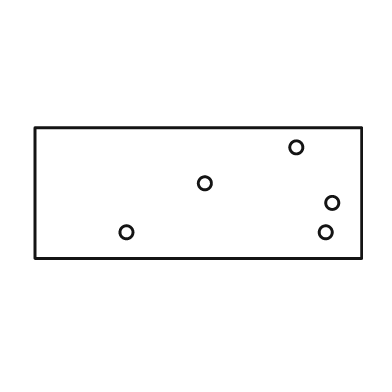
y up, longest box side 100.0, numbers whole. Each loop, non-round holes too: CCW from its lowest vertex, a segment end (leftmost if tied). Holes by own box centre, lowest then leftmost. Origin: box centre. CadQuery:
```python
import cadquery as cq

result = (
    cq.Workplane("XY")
    .moveTo(-50.0, -20.0)
    .lineTo(50.0, -20.0)
    .lineTo(50.0, 20.0)
    .lineTo(-50.0, 20.0)
    .close()
    .moveTo(-22.0, -12.0)
    .circle(2.0)
    .moveTo(39.0, -12.0)
    .circle(2.0)
    .moveTo(41.0, -3.0)
    .circle(2.0)
    .moveTo(2.0, 3.0)
    .circle(2.0)
    .moveTo(30.0, 14.0)
    .circle(2.0)
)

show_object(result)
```